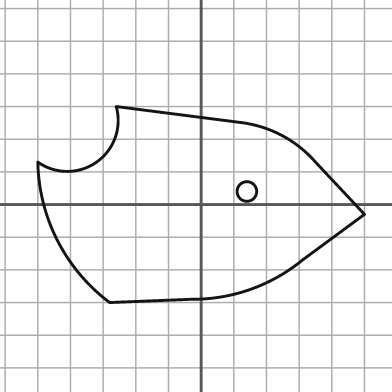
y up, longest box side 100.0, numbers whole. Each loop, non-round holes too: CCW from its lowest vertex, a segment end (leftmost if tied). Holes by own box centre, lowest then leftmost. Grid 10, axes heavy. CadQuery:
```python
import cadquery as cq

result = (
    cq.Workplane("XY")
    .moveTo(-28.0, -30.0)
    .lineTo(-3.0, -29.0)
    .threePointArc((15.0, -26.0), (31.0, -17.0))
    .lineTo(50.0, -3.0)
    .lineTo(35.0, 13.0)
    .threePointArc((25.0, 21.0), (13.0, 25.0))
    .lineTo(-26.0, 30.0)
    .threePointArc((-32.0, 13.0), (-50.0, 13.0))
    .threePointArc((-44.0, -11.0), (-28.0, -30.0))
    .close()
    .moveTo(14.0, 4.0)
    .circle(3.0)
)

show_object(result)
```